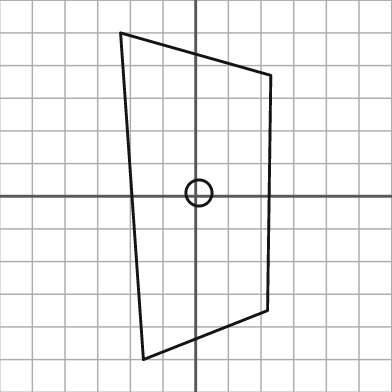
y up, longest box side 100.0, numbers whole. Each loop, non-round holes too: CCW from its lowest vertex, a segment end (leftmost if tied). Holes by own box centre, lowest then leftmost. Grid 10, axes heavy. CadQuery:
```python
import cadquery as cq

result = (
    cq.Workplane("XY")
    .moveTo(-16.0, -50.0)
    .lineTo(22.0, -35.0)
    .lineTo(23.0, 37.0)
    .lineTo(-23.0, 50.0)
    .close()
    .moveTo(1.0, 1.0)
    .circle(4.0)
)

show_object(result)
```